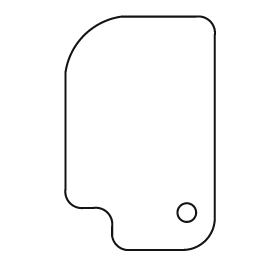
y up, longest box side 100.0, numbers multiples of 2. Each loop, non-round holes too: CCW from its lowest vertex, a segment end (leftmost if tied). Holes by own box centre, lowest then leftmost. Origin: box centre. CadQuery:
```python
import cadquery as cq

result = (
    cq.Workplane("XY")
    .moveTo(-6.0, -50.0)
    .lineTo(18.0, -50.0)
    .threePointArc((28.0, -46.0), (32.0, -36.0))
    .lineTo(32.0, 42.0)
    .threePointArc((30.0, 48.0), (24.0, 50.0))
    .lineTo(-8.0, 50.0)
    .threePointArc((-24.0, 42.0), (-32.0, 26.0))
    .lineTo(-32.0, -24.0)
    .threePointArc((-30.0, -30.0), (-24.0, -32.0))
    .lineTo(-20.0, -32.0)
    .threePointArc((-14.0, -34.0), (-12.0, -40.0))
    .lineTo(-12.0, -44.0)
    .threePointArc((-10.0, -48.0), (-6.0, -50.0))
    .close()
    .moveTo(20.0, -34.0)
    .circle(4.0)
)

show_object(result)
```